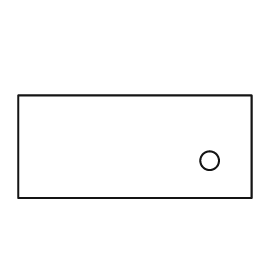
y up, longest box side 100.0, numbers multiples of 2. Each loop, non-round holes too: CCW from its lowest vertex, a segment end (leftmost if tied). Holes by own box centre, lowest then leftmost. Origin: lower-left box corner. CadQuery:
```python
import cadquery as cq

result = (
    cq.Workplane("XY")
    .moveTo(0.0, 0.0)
    .lineTo(100.0, 0.0)
    .lineTo(100.0, 44.0)
    .lineTo(0.0, 44.0)
    .close()
    .moveTo(82.0, 16.0)
    .circle(4.0)
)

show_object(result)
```